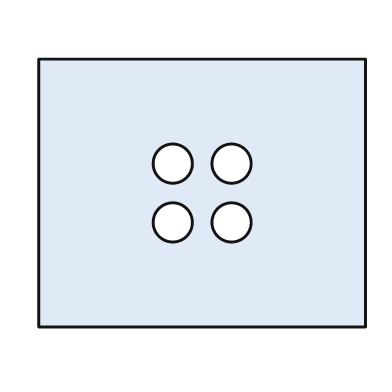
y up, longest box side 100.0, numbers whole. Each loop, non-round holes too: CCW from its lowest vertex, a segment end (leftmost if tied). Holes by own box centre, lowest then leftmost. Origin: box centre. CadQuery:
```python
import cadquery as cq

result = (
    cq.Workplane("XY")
    .moveTo(-50.0, -41.0)
    .lineTo(50.0, -41.0)
    .lineTo(50.0, 41.0)
    .lineTo(-50.0, 41.0)
    .close()
    .moveTo(-9.0, -9.0)
    .circle(6.0)
    .moveTo(9.0, -9.0)
    .circle(6.0)
    .moveTo(-9.0, 9.0)
    .circle(6.0)
    .moveTo(9.0, 9.0)
    .circle(6.0)
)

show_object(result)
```